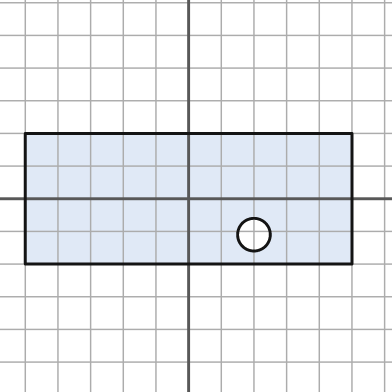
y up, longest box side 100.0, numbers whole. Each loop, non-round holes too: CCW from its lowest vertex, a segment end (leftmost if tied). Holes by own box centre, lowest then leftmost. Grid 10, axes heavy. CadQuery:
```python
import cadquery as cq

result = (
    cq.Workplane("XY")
    .moveTo(-50.0, -20.0)
    .lineTo(50.0, -20.0)
    .lineTo(50.0, 20.0)
    .lineTo(-50.0, 20.0)
    .close()
    .moveTo(20.0, -11.0)
    .circle(5.0)
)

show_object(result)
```